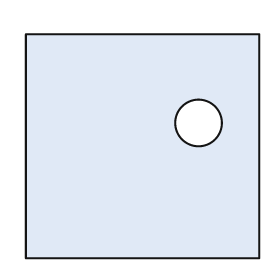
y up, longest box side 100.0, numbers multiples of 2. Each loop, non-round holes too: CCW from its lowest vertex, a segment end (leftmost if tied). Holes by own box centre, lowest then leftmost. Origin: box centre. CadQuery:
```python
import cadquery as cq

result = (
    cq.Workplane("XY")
    .moveTo(-50.0, -48.0)
    .lineTo(50.0, -48.0)
    .lineTo(50.0, 48.0)
    .lineTo(-50.0, 48.0)
    .close()
    .moveTo(24.0, 10.0)
    .circle(10.0)
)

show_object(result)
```